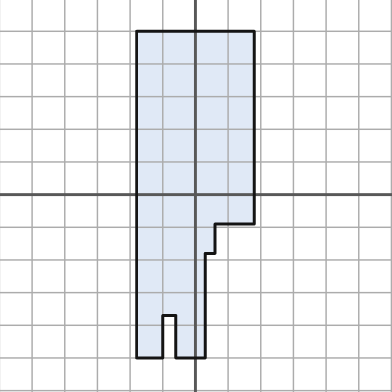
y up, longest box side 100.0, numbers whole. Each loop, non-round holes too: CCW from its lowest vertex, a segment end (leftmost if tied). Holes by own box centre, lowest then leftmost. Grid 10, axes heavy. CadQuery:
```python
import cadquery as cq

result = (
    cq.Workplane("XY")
    .moveTo(-18.0, -50.0)
    .lineTo(-10.0, -50.0)
    .lineTo(-10.0, -37.0)
    .lineTo(-6.0, -37.0)
    .lineTo(-6.0, -50.0)
    .lineTo(3.0, -50.0)
    .lineTo(3.0, -18.0)
    .lineTo(6.0, -18.0)
    .lineTo(6.0, -9.0)
    .lineTo(18.0, -9.0)
    .lineTo(18.0, 50.0)
    .lineTo(-18.0, 50.0)
    .close()
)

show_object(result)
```